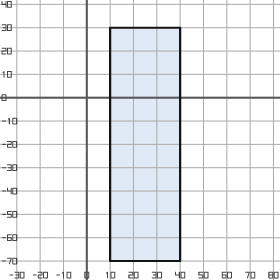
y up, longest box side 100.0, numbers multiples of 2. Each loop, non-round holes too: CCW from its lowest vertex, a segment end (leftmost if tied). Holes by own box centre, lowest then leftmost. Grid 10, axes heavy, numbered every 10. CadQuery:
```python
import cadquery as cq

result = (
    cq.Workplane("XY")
    .moveTo(10.0, -70.0)
    .lineTo(40.0, -70.0)
    .lineTo(40.0, 30.0)
    .lineTo(10.0, 30.0)
    .close()
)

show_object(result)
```